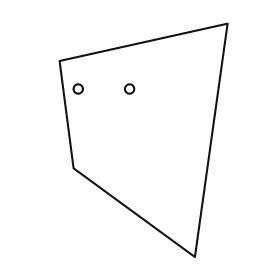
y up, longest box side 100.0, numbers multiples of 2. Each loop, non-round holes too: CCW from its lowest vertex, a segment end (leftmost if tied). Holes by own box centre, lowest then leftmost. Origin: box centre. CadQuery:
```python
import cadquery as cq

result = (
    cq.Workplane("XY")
    .moveTo(22.0, -50.0)
    .lineTo(36.0, 50.0)
    .lineTo(-36.0, 34.0)
    .lineTo(-30.0, -12.0)
    .close()
    .moveTo(-28.0, 22.0)
    .circle(2.0)
    .moveTo(-6.0, 22.0)
    .circle(2.0)
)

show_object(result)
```